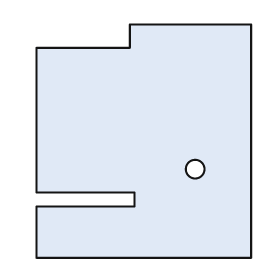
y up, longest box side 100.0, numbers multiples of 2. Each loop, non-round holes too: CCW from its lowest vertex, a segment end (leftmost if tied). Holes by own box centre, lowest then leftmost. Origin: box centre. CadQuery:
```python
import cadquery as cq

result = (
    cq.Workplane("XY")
    .moveTo(-46.0, -50.0)
    .lineTo(46.0, -50.0)
    .lineTo(46.0, 50.0)
    .lineTo(-6.0, 50.0)
    .lineTo(-6.0, 40.0)
    .lineTo(-46.0, 40.0)
    .lineTo(-46.0, -22.0)
    .lineTo(-4.0, -22.0)
    .lineTo(-4.0, -28.0)
    .lineTo(-46.0, -28.0)
    .close()
    .moveTo(22.0, -12.0)
    .circle(4.0)
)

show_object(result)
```